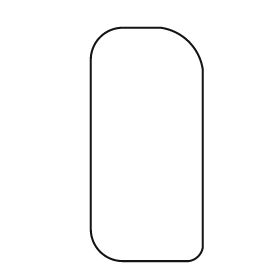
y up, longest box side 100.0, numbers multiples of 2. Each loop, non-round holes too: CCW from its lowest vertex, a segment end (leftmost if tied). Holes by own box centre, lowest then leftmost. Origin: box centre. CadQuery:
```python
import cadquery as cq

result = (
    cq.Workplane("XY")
    .moveTo(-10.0, -50.0)
    .lineTo(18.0, -50.0)
    .threePointArc((22.0, -48.0), (24.0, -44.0))
    .lineTo(24.0, 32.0)
    .threePointArc((18.0, 44.0), (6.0, 50.0))
    .lineTo(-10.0, 50.0)
    .threePointArc((-20.0, 46.0), (-24.0, 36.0))
    .lineTo(-24.0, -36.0)
    .threePointArc((-20.0, -46.0), (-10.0, -50.0))
    .close()
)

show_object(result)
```